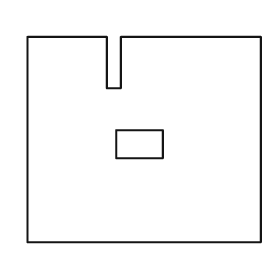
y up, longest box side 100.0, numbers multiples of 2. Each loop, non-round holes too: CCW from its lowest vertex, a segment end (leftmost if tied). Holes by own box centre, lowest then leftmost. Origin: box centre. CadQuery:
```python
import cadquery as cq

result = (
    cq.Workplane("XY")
    .moveTo(-50.0, -44.0)
    .lineTo(50.0, -44.0)
    .lineTo(50.0, 44.0)
    .lineTo(-10.0, 44.0)
    .lineTo(-10.0, 22.0)
    .lineTo(-16.0, 22.0)
    .lineTo(-16.0, 44.0)
    .lineTo(-50.0, 44.0)
    .close()
    .moveTo(-12.0, -8.0)
    .lineTo(8.0, -8.0)
    .lineTo(8.0, 4.0)
    .lineTo(-12.0, 4.0)
    .close()
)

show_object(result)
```